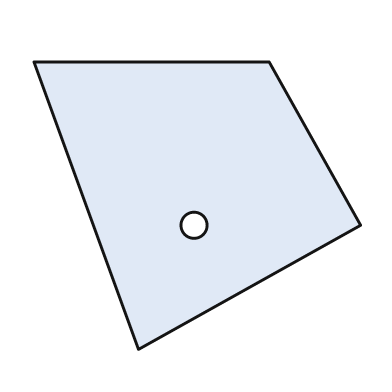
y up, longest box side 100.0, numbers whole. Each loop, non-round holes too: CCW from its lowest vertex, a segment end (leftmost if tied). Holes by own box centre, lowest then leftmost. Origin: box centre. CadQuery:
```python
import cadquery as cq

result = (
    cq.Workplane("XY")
    .moveTo(-18.0, -44.0)
    .lineTo(50.0, -6.0)
    .lineTo(22.0, 44.0)
    .lineTo(-50.0, 44.0)
    .close()
    .moveTo(-1.0, -6.0)
    .circle(4.0)
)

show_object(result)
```